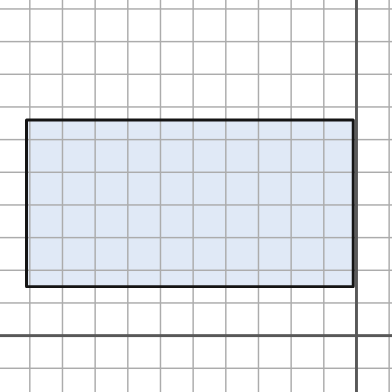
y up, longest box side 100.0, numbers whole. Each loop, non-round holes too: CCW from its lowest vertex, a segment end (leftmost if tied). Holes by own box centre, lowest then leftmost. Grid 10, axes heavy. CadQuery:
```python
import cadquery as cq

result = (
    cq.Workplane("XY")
    .moveTo(-101.0, 15.0)
    .lineTo(-1.0, 15.0)
    .lineTo(-1.0, 66.0)
    .lineTo(-101.0, 66.0)
    .close()
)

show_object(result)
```